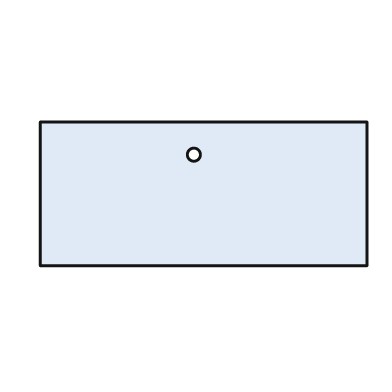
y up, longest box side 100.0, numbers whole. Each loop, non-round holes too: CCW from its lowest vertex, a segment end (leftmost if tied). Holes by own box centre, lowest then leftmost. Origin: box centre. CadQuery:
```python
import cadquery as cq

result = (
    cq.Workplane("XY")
    .moveTo(-50.0, -22.0)
    .lineTo(50.0, -22.0)
    .lineTo(50.0, 22.0)
    .lineTo(-50.0, 22.0)
    .close()
    .moveTo(-3.0, 12.0)
    .circle(2.0)
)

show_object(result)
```